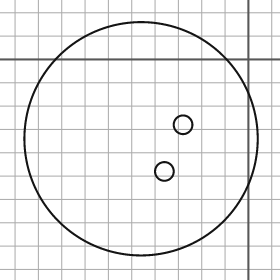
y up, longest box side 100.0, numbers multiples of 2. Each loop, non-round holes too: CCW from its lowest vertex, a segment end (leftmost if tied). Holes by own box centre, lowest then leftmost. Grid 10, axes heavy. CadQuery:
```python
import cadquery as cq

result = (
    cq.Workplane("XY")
    .moveTo(-46.0, -34.0)
    .circle(50.0)
    .moveTo(-36.0, -48.0)
    .circle(4.0)
    .moveTo(-28.0, -28.0)
    .circle(4.0)
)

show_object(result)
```